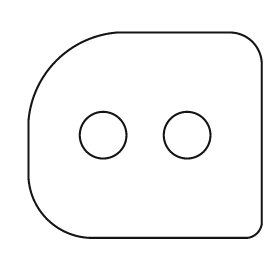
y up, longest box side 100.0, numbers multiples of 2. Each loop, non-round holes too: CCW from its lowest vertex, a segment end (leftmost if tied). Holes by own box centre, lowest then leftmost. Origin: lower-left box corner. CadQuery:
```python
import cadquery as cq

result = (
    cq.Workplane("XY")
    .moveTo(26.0, 0.0)
    .lineTo(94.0, 0.0)
    .threePointArc((98.0, 2.0), (100.0, 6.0))
    .lineTo(100.0, 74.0)
    .threePointArc((96.0, 84.0), (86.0, 88.0))
    .lineTo(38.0, 88.0)
    .threePointArc((12.0, 76.0), (0.0, 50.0))
    .lineTo(0.0, 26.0)
    .threePointArc((8.0, 8.0), (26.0, 0.0))
    .close()
    .moveTo(32.0, 44.0)
    .circle(10.0)
    .moveTo(68.0, 44.0)
    .circle(10.0)
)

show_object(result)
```